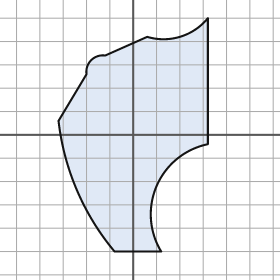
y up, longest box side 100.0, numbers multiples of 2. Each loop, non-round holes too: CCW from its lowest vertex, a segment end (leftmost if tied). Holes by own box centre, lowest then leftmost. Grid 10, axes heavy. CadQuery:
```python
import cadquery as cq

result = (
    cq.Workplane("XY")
    .moveTo(-8.0, -50.0)
    .lineTo(12.0, -50.0)
    .threePointArc((10.0, -22.0), (32.0, -4.0))
    .lineTo(32.0, 50.0)
    .threePointArc((20.0, 42.0), (6.0, 42.0))
    .lineTo(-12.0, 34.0)
    .threePointArc((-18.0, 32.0), (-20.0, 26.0))
    .lineTo(-32.0, 6.0)
    .threePointArc((-24.0, -24.0), (-8.0, -50.0))
    .close()
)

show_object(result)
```